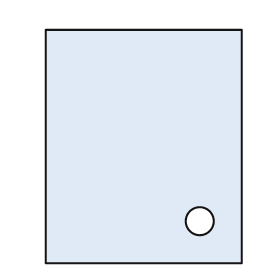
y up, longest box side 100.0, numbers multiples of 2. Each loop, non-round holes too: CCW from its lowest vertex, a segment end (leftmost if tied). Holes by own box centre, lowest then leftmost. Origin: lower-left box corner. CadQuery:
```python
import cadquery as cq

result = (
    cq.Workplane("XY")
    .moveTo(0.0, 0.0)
    .lineTo(84.0, 0.0)
    .lineTo(84.0, 100.0)
    .lineTo(0.0, 100.0)
    .close()
    .moveTo(66.0, 18.0)
    .circle(6.0)
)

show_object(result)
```